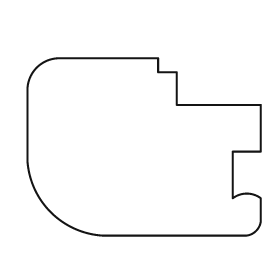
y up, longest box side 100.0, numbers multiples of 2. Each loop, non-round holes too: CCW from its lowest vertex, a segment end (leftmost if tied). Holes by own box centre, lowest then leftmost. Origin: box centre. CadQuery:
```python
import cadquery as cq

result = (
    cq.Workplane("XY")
    .moveTo(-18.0, -38.0)
    .lineTo(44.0, -38.0)
    .threePointArc((48.0, -36.0), (50.0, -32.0))
    .lineTo(50.0, -22.0)
    .threePointArc((44.0, -20.0), (38.0, -22.0))
    .lineTo(38.0, -2.0)
    .lineTo(50.0, -2.0)
    .lineTo(50.0, 18.0)
    .lineTo(14.0, 18.0)
    .lineTo(14.0, 32.0)
    .lineTo(6.0, 32.0)
    .lineTo(6.0, 38.0)
    .lineTo(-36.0, 38.0)
    .threePointArc((-46.0, 34.0), (-50.0, 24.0))
    .lineTo(-50.0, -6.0)
    .threePointArc((-40.0, -28.0), (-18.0, -38.0))
    .close()
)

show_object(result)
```